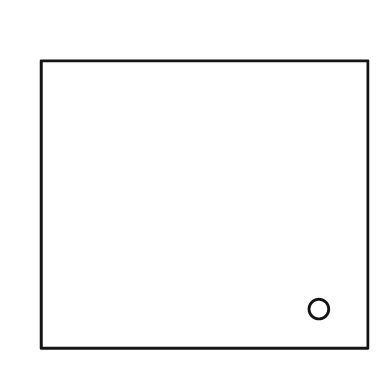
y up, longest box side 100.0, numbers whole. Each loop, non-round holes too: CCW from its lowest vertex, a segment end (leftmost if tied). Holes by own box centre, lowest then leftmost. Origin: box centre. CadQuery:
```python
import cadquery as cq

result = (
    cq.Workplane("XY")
    .moveTo(-50.0, -44.0)
    .lineTo(50.0, -44.0)
    .lineTo(50.0, 44.0)
    .lineTo(-50.0, 44.0)
    .close()
    .moveTo(35.0, -32.0)
    .circle(3.0)
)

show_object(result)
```